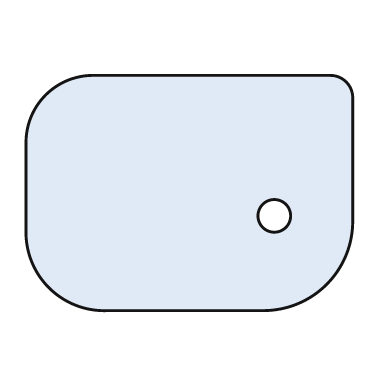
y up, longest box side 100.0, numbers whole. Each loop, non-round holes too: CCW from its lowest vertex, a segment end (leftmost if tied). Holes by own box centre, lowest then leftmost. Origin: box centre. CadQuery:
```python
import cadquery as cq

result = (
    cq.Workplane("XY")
    .moveTo(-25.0, -36.0)
    .lineTo(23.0, -36.0)
    .threePointArc((42.0, -28.0), (50.0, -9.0))
    .lineTo(50.0, 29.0)
    .threePointArc((48.0, 34.0), (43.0, 36.0))
    .lineTo(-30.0, 36.0)
    .threePointArc((-44.0, 30.0), (-50.0, 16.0))
    .lineTo(-50.0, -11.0)
    .threePointArc((-43.0, -29.0), (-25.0, -36.0))
    .close()
    .moveTo(26.0, -7.0)
    .circle(5.0)
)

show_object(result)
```